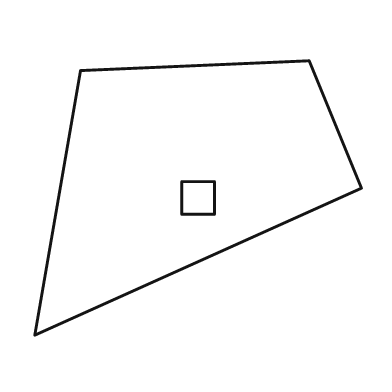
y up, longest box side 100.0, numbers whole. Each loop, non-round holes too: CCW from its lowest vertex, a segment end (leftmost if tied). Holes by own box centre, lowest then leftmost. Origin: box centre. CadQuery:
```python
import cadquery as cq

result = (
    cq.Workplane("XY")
    .moveTo(-50.0, -42.0)
    .lineTo(50.0, 3.0)
    .lineTo(34.0, 42.0)
    .lineTo(-36.0, 39.0)
    .close()
    .moveTo(-5.0, -5.0)
    .lineTo(5.0, -5.0)
    .lineTo(5.0, 5.0)
    .lineTo(-5.0, 5.0)
    .close()
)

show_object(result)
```